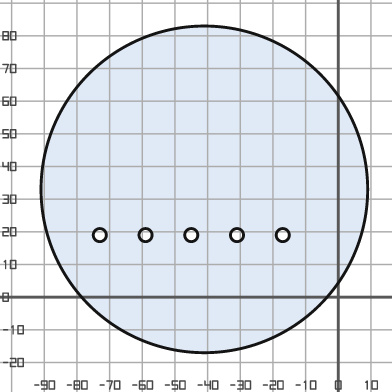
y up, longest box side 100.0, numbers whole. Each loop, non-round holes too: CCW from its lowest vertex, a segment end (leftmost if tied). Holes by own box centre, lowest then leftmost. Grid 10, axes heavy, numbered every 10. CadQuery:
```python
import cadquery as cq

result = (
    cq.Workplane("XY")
    .moveTo(-41.0, 33.0)
    .circle(50.0)
    .moveTo(-73.0, 19.0)
    .circle(2.0)
    .moveTo(-59.0, 19.0)
    .circle(2.0)
    .moveTo(-45.0, 19.0)
    .circle(2.0)
    .moveTo(-31.0, 19.0)
    .circle(2.0)
    .moveTo(-17.0, 19.0)
    .circle(2.0)
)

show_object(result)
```